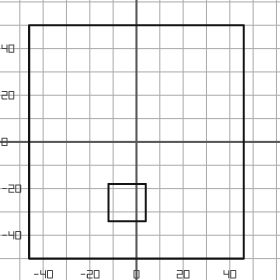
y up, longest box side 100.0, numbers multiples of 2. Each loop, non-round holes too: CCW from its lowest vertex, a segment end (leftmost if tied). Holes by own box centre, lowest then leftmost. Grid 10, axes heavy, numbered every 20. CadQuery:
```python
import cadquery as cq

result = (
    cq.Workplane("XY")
    .moveTo(-46.0, -50.0)
    .lineTo(46.0, -50.0)
    .lineTo(46.0, 50.0)
    .lineTo(-46.0, 50.0)
    .close()
    .moveTo(-12.0, -34.0)
    .lineTo(4.0, -34.0)
    .lineTo(4.0, -18.0)
    .lineTo(-12.0, -18.0)
    .close()
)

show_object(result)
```